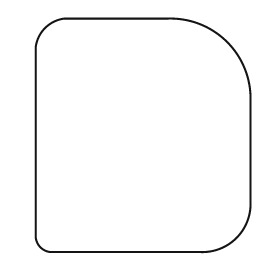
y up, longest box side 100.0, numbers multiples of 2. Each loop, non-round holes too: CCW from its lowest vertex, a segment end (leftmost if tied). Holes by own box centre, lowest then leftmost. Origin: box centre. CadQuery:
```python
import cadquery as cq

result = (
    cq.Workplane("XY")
    .moveTo(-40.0, -50.0)
    .lineTo(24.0, -50.0)
    .threePointArc((40.0, -44.0), (46.0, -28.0))
    .lineTo(46.0, 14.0)
    .threePointArc((36.0, 40.0), (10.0, 50.0))
    .lineTo(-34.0, 50.0)
    .threePointArc((-42.0, 46.0), (-46.0, 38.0))
    .lineTo(-46.0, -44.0)
    .threePointArc((-44.0, -48.0), (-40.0, -50.0))
    .close()
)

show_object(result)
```